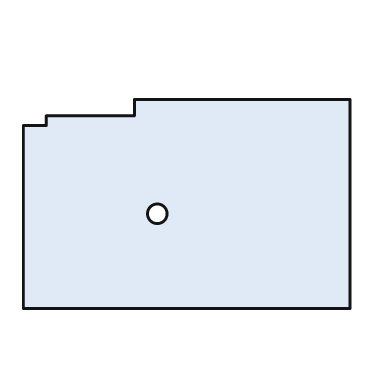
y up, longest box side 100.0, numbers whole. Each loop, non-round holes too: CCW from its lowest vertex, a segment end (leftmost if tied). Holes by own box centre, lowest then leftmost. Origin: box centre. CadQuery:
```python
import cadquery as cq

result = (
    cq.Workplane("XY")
    .moveTo(-50.0, -32.0)
    .lineTo(50.0, -32.0)
    .lineTo(50.0, 32.0)
    .lineTo(-16.0, 32.0)
    .lineTo(-16.0, 27.0)
    .lineTo(-43.0, 27.0)
    .lineTo(-43.0, 24.0)
    .lineTo(-50.0, 24.0)
    .close()
    .moveTo(-9.0, -3.0)
    .circle(3.0)
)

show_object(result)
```